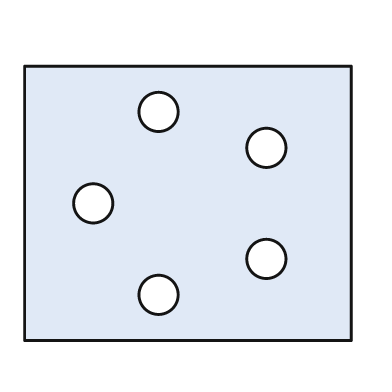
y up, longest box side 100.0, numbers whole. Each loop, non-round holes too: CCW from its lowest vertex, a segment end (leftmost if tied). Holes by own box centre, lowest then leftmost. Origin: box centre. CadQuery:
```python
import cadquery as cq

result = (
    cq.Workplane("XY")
    .moveTo(-50.0, -42.0)
    .lineTo(50.0, -42.0)
    .lineTo(50.0, 42.0)
    .lineTo(-50.0, 42.0)
    .close()
    .moveTo(-9.0, -28.0)
    .circle(6.0)
    .moveTo(24.0, -17.0)
    .circle(6.0)
    .moveTo(-29.0, 0.0)
    .circle(6.0)
    .moveTo(24.0, 17.0)
    .circle(6.0)
    .moveTo(-9.0, 28.0)
    .circle(6.0)
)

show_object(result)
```